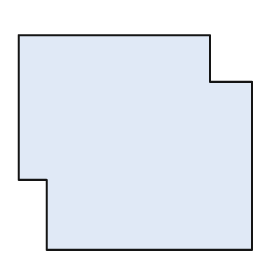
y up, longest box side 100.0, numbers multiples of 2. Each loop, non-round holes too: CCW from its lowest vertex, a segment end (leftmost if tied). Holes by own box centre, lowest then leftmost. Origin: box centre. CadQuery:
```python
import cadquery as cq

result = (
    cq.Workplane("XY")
    .moveTo(-38.0, -46.0)
    .lineTo(50.0, -46.0)
    .lineTo(50.0, 26.0)
    .lineTo(32.0, 26.0)
    .lineTo(32.0, 46.0)
    .lineTo(-50.0, 46.0)
    .lineTo(-50.0, -16.0)
    .lineTo(-38.0, -16.0)
    .close()
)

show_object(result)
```